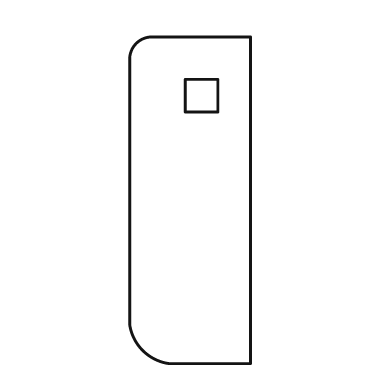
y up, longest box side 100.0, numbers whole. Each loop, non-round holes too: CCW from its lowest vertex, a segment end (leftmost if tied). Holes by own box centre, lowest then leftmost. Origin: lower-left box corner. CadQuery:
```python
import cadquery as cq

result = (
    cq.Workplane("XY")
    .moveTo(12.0, 0.0)
    .lineTo(37.0, 0.0)
    .lineTo(37.0, 100.0)
    .lineTo(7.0, 100.0)
    .threePointArc((2.0, 98.0), (0.0, 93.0))
    .lineTo(0.0, 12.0)
    .threePointArc((4.0, 4.0), (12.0, 0.0))
    .close()
    .moveTo(17.0, 77.0)
    .lineTo(27.0, 77.0)
    .lineTo(27.0, 87.0)
    .lineTo(17.0, 87.0)
    .close()
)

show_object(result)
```